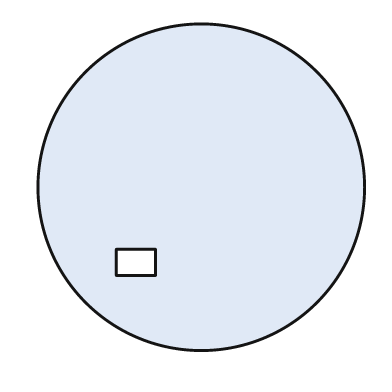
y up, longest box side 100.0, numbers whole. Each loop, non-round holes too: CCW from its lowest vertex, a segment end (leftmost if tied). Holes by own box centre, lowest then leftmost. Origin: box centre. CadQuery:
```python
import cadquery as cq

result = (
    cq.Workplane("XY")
    .moveTo(0.0, 0.0)
    .circle(50.0)
    .moveTo(-26.0, -27.0)
    .lineTo(-14.0, -27.0)
    .lineTo(-14.0, -19.0)
    .lineTo(-26.0, -19.0)
    .close()
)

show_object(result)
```